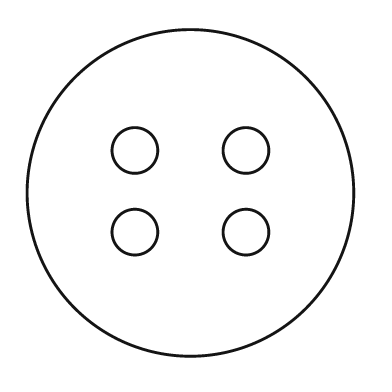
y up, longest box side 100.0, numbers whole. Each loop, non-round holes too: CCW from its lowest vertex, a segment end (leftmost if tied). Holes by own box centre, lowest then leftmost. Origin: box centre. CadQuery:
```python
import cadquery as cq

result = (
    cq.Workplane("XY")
    .moveTo(0.0, 0.0)
    .circle(50.0)
    .moveTo(-17.0, -12.0)
    .circle(7.0)
    .moveTo(17.0, -12.0)
    .circle(7.0)
    .moveTo(-17.0, 13.0)
    .circle(7.0)
    .moveTo(17.0, 13.0)
    .circle(7.0)
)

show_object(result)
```